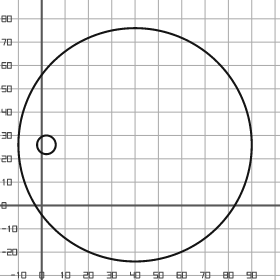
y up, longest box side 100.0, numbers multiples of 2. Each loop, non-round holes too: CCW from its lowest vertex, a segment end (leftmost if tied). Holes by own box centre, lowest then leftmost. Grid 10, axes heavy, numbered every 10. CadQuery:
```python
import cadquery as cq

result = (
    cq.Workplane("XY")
    .moveTo(40.0, 26.0)
    .circle(50.0)
    .moveTo(2.0, 26.0)
    .circle(4.0)
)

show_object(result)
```